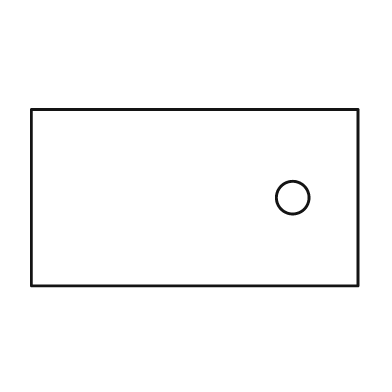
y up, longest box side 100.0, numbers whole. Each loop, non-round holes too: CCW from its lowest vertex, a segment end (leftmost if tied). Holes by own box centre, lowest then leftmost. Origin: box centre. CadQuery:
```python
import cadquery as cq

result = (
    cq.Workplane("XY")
    .moveTo(-50.0, -27.0)
    .lineTo(50.0, -27.0)
    .lineTo(50.0, 27.0)
    .lineTo(-50.0, 27.0)
    .close()
    .moveTo(30.0, 0.0)
    .circle(5.0)
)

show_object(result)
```